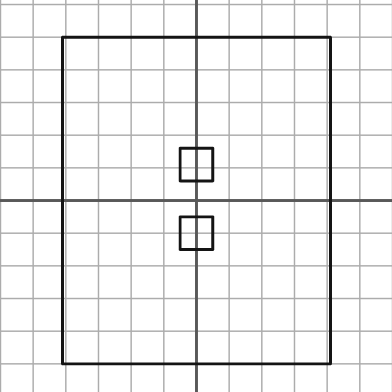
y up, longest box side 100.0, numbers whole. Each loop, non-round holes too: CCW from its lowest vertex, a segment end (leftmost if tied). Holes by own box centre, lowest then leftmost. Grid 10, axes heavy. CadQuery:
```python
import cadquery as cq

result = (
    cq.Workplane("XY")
    .moveTo(-41.0, -50.0)
    .lineTo(41.0, -50.0)
    .lineTo(41.0, 50.0)
    .lineTo(-41.0, 50.0)
    .close()
    .moveTo(-5.0, -15.0)
    .lineTo(5.0, -15.0)
    .lineTo(5.0, -5.0)
    .lineTo(-5.0, -5.0)
    .close()
    .moveTo(-5.0, 6.0)
    .lineTo(5.0, 6.0)
    .lineTo(5.0, 16.0)
    .lineTo(-5.0, 16.0)
    .close()
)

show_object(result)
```